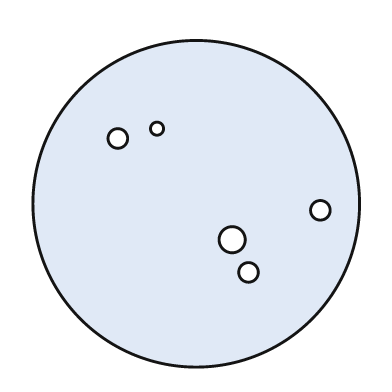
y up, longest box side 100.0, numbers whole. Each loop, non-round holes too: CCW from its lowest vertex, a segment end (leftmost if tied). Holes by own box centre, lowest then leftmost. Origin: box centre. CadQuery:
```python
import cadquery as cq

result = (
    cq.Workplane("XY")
    .moveTo(0.0, 0.0)
    .circle(50.0)
    .moveTo(16.0, -21.0)
    .circle(3.0)
    .moveTo(11.0, -11.0)
    .circle(4.0)
    .moveTo(38.0, -2.0)
    .circle(3.0)
    .moveTo(-24.0, 20.0)
    .circle(3.0)
    .moveTo(-12.0, 23.0)
    .circle(2.0)
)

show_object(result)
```